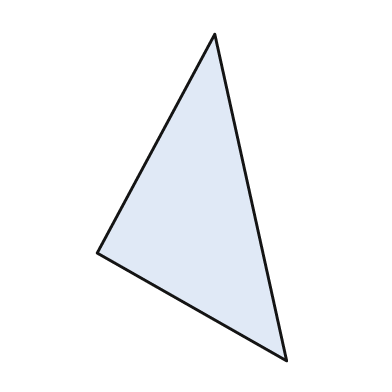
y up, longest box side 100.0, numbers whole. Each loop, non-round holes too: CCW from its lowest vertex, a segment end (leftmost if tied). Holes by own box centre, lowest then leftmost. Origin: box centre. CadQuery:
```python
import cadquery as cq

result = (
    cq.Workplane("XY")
    .moveTo(29.0, -50.0)
    .lineTo(7.0, 50.0)
    .lineTo(-29.0, -17.0)
    .close()
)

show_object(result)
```